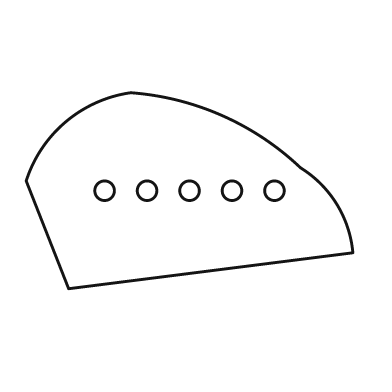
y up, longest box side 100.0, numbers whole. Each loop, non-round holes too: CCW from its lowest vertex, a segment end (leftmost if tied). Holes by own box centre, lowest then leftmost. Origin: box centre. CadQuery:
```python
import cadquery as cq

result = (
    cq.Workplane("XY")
    .moveTo(-37.0, -30.0)
    .lineTo(50.0, -19.0)
    .threePointArc((45.0, -4.0), (34.0, 7.0))
    .threePointArc((10.0, 23.0), (-18.0, 30.0))
    .threePointArc((-38.0, 21.0), (-50.0, 3.0))
    .close()
    .moveTo(-26.0, 0.0)
    .circle(3.0)
    .moveTo(-13.0, 0.0)
    .circle(3.0)
    .moveTo(0.0, 0.0)
    .circle(3.0)
    .moveTo(13.0, 0.0)
    .circle(3.0)
    .moveTo(26.0, 0.0)
    .circle(3.0)
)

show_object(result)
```